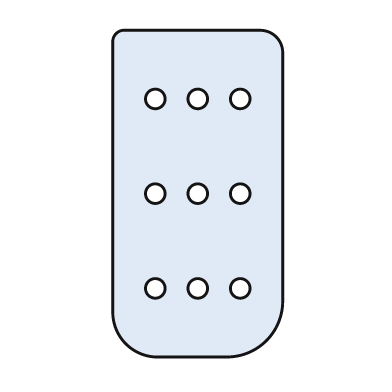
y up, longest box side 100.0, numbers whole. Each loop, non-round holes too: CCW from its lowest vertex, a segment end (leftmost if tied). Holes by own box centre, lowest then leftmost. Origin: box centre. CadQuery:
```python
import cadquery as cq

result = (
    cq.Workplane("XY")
    .moveTo(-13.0, -50.0)
    .lineTo(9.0, -50.0)
    .threePointArc((21.0, -45.0), (26.0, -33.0))
    .lineTo(26.0, 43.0)
    .threePointArc((24.0, 48.0), (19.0, 50.0))
    .lineTo(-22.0, 50.0)
    .threePointArc((-25.0, 49.0), (-26.0, 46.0))
    .lineTo(-26.0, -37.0)
    .threePointArc((-22.0, -46.0), (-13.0, -50.0))
    .close()
    .moveTo(-13.0, -29.0)
    .circle(3.0)
    .moveTo(0.0, -29.0)
    .circle(3.0)
    .moveTo(13.0, -29.0)
    .circle(3.0)
    .moveTo(-13.0, 0.0)
    .circle(3.0)
    .moveTo(0.0, 0.0)
    .circle(3.0)
    .moveTo(13.0, 0.0)
    .circle(3.0)
    .moveTo(-13.0, 29.0)
    .circle(3.0)
    .moveTo(0.0, 29.0)
    .circle(3.0)
    .moveTo(13.0, 29.0)
    .circle(3.0)
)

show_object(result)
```